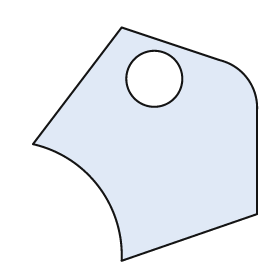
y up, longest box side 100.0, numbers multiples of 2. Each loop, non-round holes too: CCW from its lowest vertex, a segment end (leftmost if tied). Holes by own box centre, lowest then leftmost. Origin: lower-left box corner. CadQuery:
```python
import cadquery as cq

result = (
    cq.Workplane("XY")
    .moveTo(38.0, 0.0)
    .lineTo(96.0, 20.0)
    .lineTo(96.0, 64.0)
    .threePointArc((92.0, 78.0), (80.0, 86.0))
    .lineTo(38.0, 100.0)
    .lineTo(0.0, 50.0)
    .threePointArc((28.0, 32.0), (38.0, 0.0))
    .close()
    .moveTo(52.0, 78.0)
    .circle(12.0)
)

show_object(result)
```